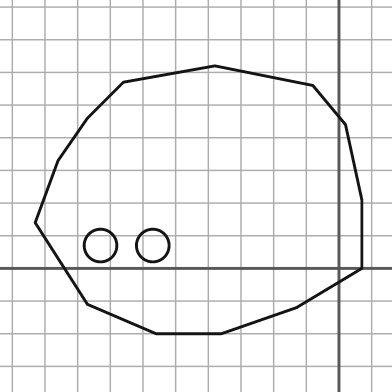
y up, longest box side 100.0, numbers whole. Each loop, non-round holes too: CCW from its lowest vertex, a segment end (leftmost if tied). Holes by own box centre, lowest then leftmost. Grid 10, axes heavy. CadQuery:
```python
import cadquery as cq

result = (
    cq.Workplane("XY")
    .moveTo(-56.0, -20.0)
    .lineTo(-36.0, -20.0)
    .lineTo(-13.0, -12.0)
    .lineTo(7.0, 0.0)
    .lineTo(7.0, 21.0)
    .lineTo(2.0, 44.0)
    .lineTo(-8.0, 56.0)
    .lineTo(-38.0, 62.0)
    .lineTo(-66.0, 57.0)
    .lineTo(-77.0, 46.0)
    .lineTo(-86.0, 33.0)
    .lineTo(-93.0, 14.0)
    .lineTo(-77.0, -11.0)
    .close()
    .moveTo(-73.0, 7.0)
    .circle(5.0)
    .moveTo(-57.0, 7.0)
    .circle(5.0)
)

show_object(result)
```